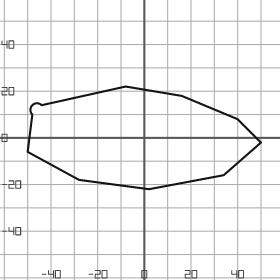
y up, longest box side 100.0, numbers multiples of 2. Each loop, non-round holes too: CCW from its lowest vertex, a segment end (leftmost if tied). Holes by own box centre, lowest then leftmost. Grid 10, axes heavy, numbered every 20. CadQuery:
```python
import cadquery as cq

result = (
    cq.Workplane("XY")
    .moveTo(2.0, -22.0)
    .lineTo(34.0, -16.0)
    .lineTo(50.0, -2.0)
    .lineTo(40.0, 8.0)
    .lineTo(16.0, 18.0)
    .lineTo(-8.0, 22.0)
    .lineTo(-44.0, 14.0)
    .threePointArc((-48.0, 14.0), (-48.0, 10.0))
    .lineTo(-50.0, -6.0)
    .lineTo(-28.0, -18.0)
    .close()
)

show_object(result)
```